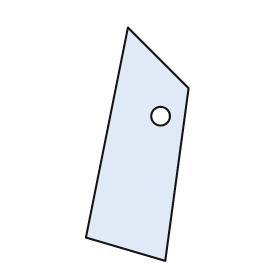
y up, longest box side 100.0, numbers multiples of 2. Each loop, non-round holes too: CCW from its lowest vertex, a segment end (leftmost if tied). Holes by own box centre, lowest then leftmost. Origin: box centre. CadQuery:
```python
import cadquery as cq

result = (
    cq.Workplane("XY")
    .moveTo(12.0, -50.0)
    .lineTo(22.0, 24.0)
    .lineTo(-4.0, 50.0)
    .lineTo(-22.0, -40.0)
    .close()
    .moveTo(10.0, 12.0)
    .circle(4.0)
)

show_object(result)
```